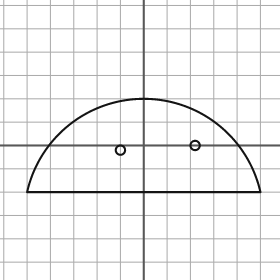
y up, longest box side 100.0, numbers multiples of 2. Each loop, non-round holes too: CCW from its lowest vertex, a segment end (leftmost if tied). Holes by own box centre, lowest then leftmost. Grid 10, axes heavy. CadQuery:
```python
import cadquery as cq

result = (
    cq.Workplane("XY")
    .moveTo(-50.0, -20.0)
    .lineTo(50.0, -20.0)
    .threePointArc((0.0, 20.0), (-50.0, -20.0))
    .close()
    .moveTo(-10.0, -2.0)
    .circle(2.0)
    .moveTo(22.0, 0.0)
    .circle(2.0)
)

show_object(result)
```